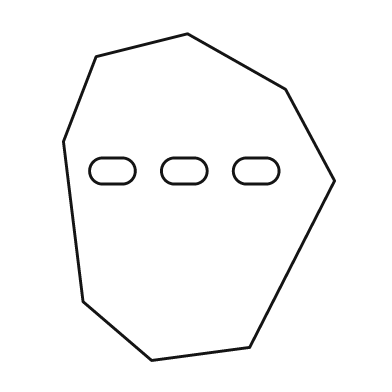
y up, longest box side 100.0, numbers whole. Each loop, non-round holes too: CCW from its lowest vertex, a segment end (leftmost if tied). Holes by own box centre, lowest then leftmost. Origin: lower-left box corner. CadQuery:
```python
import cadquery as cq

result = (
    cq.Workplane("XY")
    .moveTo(27.0, 0.0)
    .lineTo(57.0, 4.0)
    .lineTo(83.0, 55.0)
    .lineTo(68.0, 83.0)
    .lineTo(38.0, 100.0)
    .lineTo(10.0, 93.0)
    .lineTo(0.0, 67.0)
    .lineTo(6.0, 18.0)
    .close()
    .moveTo(12.0, 54.0)
    .lineTo(18.0, 54.0)
    .threePointArc((22.0, 58.0), (18.0, 62.0))
    .lineTo(12.0, 62.0)
    .threePointArc((8.0, 58.0), (12.0, 54.0))
    .close()
    .moveTo(34.0, 54.0)
    .lineTo(40.0, 54.0)
    .threePointArc((44.0, 58.0), (40.0, 62.0))
    .lineTo(34.0, 62.0)
    .threePointArc((30.0, 58.0), (34.0, 54.0))
    .close()
    .moveTo(56.0, 54.0)
    .lineTo(62.0, 54.0)
    .threePointArc((66.0, 58.0), (62.0, 62.0))
    .lineTo(56.0, 62.0)
    .threePointArc((52.0, 58.0), (56.0, 54.0))
    .close()
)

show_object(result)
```